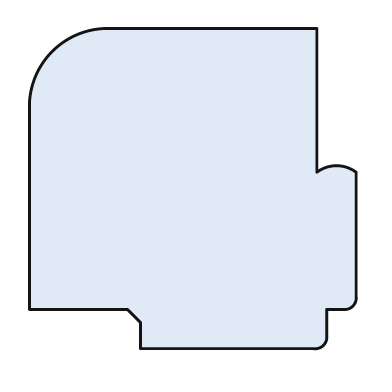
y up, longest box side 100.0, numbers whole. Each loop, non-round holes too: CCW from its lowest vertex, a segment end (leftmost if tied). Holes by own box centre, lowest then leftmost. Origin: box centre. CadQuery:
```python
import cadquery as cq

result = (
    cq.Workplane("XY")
    .moveTo(-16.0, -49.0)
    .lineTo(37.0, -49.0)
    .threePointArc((40.0, -48.0), (41.0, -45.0))
    .lineTo(41.0, -37.0)
    .lineTo(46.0, -37.0)
    .threePointArc((49.0, -36.0), (50.0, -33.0))
    .lineTo(50.0, 5.0)
    .threePointArc((44.0, 7.0), (38.0, 5.0))
    .lineTo(38.0, 49.0)
    .lineTo(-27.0, 49.0)
    .threePointArc((-43.0, 42.0), (-50.0, 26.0))
    .lineTo(-50.0, -37.0)
    .lineTo(-20.0, -37.0)
    .lineTo(-16.0, -41.0)
    .close()
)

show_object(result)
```